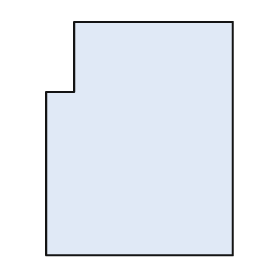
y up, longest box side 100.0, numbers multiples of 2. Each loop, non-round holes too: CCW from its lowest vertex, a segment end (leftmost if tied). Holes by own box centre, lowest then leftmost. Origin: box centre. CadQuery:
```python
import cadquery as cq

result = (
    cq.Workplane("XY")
    .moveTo(-40.0, -50.0)
    .lineTo(40.0, -50.0)
    .lineTo(40.0, 50.0)
    .lineTo(-28.0, 50.0)
    .lineTo(-28.0, 20.0)
    .lineTo(-40.0, 20.0)
    .close()
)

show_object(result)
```